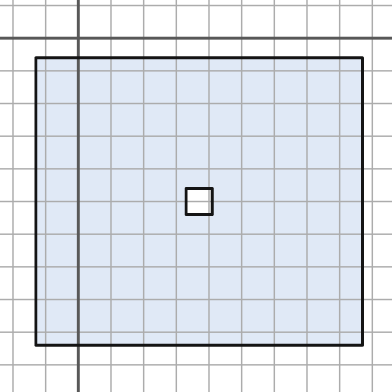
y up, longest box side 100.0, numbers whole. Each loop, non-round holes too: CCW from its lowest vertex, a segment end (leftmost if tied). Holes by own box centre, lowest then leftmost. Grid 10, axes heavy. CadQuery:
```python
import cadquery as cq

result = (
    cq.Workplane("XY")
    .moveTo(-13.0, -94.0)
    .lineTo(87.0, -94.0)
    .lineTo(87.0, -6.0)
    .lineTo(-13.0, -6.0)
    .close()
    .moveTo(33.0, -54.0)
    .lineTo(41.0, -54.0)
    .lineTo(41.0, -46.0)
    .lineTo(33.0, -46.0)
    .close()
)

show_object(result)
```